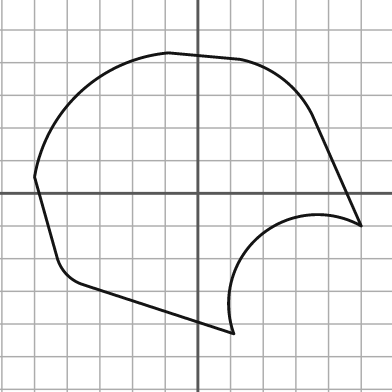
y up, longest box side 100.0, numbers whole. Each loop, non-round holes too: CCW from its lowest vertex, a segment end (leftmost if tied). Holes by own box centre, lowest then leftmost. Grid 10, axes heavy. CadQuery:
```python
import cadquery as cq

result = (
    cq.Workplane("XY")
    .moveTo(11.0, -43.0)
    .threePointArc((19.0, -13.0), (50.0, -10.0))
    .lineTo(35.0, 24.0)
    .threePointArc((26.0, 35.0), (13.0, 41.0))
    .lineTo(-9.0, 43.0)
    .threePointArc((-36.0, 31.0), (-50.0, 5.0))
    .lineTo(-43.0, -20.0)
    .threePointArc((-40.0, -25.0), (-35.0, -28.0))
    .close()
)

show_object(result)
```